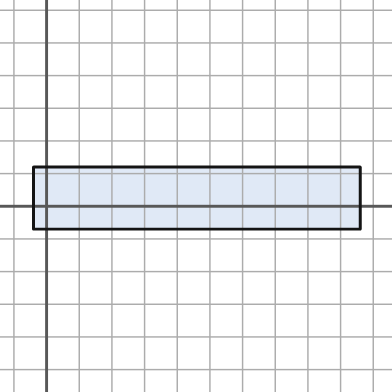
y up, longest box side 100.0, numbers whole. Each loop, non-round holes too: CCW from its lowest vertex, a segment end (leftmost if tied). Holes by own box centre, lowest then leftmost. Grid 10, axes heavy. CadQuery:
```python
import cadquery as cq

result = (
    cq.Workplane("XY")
    .moveTo(-4.0, -7.0)
    .lineTo(96.0, -7.0)
    .lineTo(96.0, 12.0)
    .lineTo(-4.0, 12.0)
    .close()
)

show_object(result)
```